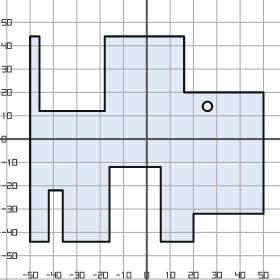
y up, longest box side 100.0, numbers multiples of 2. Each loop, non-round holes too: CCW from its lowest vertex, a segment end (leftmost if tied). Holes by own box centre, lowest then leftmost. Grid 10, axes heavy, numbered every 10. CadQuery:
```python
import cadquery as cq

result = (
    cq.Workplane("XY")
    .moveTo(-50.0, -44.0)
    .lineTo(-42.0, -44.0)
    .lineTo(-42.0, -22.0)
    .lineTo(-36.0, -22.0)
    .lineTo(-36.0, -44.0)
    .lineTo(-16.0, -44.0)
    .lineTo(-16.0, -12.0)
    .lineTo(6.0, -12.0)
    .lineTo(6.0, -44.0)
    .lineTo(20.0, -44.0)
    .lineTo(20.0, -32.0)
    .lineTo(50.0, -32.0)
    .lineTo(50.0, 20.0)
    .lineTo(16.0, 20.0)
    .lineTo(16.0, 44.0)
    .lineTo(-18.0, 44.0)
    .lineTo(-18.0, 12.0)
    .lineTo(-46.0, 12.0)
    .lineTo(-46.0, 44.0)
    .lineTo(-50.0, 44.0)
    .close()
    .moveTo(26.0, 14.0)
    .circle(2.0)
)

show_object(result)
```